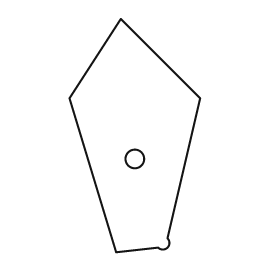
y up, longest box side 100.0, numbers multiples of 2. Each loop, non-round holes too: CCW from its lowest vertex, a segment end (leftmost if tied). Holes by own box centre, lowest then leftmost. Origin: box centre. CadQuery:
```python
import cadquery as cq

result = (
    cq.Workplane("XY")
    .moveTo(-8.0, -50.0)
    .lineTo(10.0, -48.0)
    .threePointArc((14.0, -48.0), (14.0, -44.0))
    .lineTo(28.0, 16.0)
    .lineTo(-6.0, 50.0)
    .lineTo(-28.0, 16.0)
    .close()
    .moveTo(0.0, -10.0)
    .circle(4.0)
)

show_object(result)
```